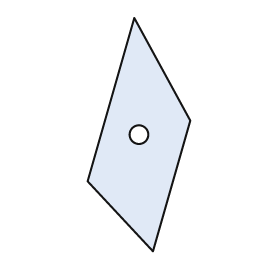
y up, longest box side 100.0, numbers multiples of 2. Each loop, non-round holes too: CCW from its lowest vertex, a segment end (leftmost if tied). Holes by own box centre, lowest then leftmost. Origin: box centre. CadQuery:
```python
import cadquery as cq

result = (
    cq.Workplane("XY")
    .moveTo(6.0, -50.0)
    .lineTo(22.0, 6.0)
    .lineTo(-2.0, 50.0)
    .lineTo(-22.0, -20.0)
    .close()
    .moveTo(0.0, 0.0)
    .circle(4.0)
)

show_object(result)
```